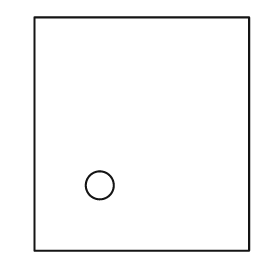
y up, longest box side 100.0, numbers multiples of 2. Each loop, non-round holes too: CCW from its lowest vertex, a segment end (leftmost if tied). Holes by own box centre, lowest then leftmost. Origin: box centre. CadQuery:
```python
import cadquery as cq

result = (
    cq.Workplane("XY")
    .moveTo(-46.0, -50.0)
    .lineTo(46.0, -50.0)
    .lineTo(46.0, 50.0)
    .lineTo(-46.0, 50.0)
    .close()
    .moveTo(-18.0, -22.0)
    .circle(6.0)
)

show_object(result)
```